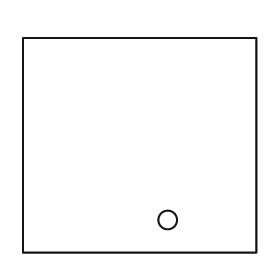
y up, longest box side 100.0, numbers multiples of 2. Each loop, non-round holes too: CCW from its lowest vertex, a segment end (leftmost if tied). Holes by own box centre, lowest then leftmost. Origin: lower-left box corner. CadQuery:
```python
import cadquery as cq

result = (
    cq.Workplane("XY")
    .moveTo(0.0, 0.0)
    .lineTo(100.0, 0.0)
    .lineTo(100.0, 92.0)
    .lineTo(0.0, 92.0)
    .close()
    .moveTo(62.0, 14.0)
    .circle(4.0)
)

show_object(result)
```